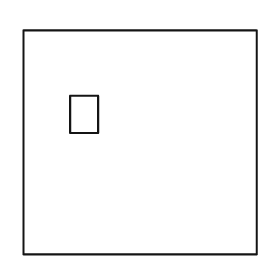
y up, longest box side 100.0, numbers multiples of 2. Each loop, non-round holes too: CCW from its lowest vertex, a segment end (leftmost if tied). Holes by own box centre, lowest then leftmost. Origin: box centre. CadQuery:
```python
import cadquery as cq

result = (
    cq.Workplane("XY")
    .moveTo(-50.0, -48.0)
    .lineTo(50.0, -48.0)
    .lineTo(50.0, 48.0)
    .lineTo(-50.0, 48.0)
    .close()
    .moveTo(-30.0, 4.0)
    .lineTo(-18.0, 4.0)
    .lineTo(-18.0, 20.0)
    .lineTo(-30.0, 20.0)
    .close()
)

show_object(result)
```